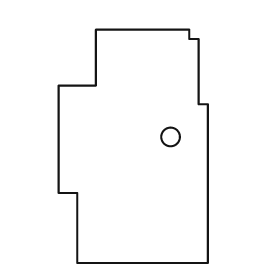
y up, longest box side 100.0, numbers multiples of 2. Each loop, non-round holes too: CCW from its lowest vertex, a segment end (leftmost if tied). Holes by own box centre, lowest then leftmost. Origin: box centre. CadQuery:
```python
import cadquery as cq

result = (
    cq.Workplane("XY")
    .moveTo(-24.0, -50.0)
    .lineTo(32.0, -50.0)
    .lineTo(32.0, 18.0)
    .lineTo(28.0, 18.0)
    .lineTo(28.0, 46.0)
    .lineTo(24.0, 46.0)
    .lineTo(24.0, 50.0)
    .lineTo(-16.0, 50.0)
    .lineTo(-16.0, 26.0)
    .lineTo(-32.0, 26.0)
    .lineTo(-32.0, -20.0)
    .lineTo(-24.0, -20.0)
    .close()
    .moveTo(16.0, 4.0)
    .circle(4.0)
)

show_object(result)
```